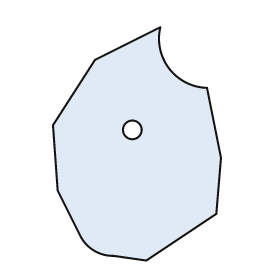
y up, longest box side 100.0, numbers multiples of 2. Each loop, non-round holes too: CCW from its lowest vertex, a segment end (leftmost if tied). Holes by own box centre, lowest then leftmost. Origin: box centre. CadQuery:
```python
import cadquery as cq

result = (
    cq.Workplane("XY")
    .moveTo(4.0, -50.0)
    .lineTo(34.0, -30.0)
    .lineTo(36.0, -6.0)
    .lineTo(30.0, 24.0)
    .threePointArc((14.0, 32.0), (10.0, 50.0))
    .lineTo(-18.0, 36.0)
    .lineTo(-36.0, 8.0)
    .lineTo(-34.0, -20.0)
    .lineTo(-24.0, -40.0)
    .threePointArc((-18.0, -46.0), (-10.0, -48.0))
    .close()
    .moveTo(-2.0, 6.0)
    .circle(4.0)
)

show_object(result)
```